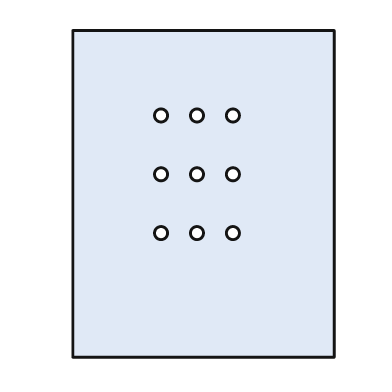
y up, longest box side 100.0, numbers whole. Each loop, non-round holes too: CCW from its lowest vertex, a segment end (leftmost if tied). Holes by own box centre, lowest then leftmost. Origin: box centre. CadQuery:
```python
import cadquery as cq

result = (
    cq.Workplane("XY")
    .moveTo(-40.0, -50.0)
    .lineTo(40.0, -50.0)
    .lineTo(40.0, 50.0)
    .lineTo(-40.0, 50.0)
    .close()
    .moveTo(-13.0, -12.0)
    .circle(2.0)
    .moveTo(-2.0, -12.0)
    .circle(2.0)
    .moveTo(9.0, -12.0)
    .circle(2.0)
    .moveTo(-13.0, 6.0)
    .circle(2.0)
    .moveTo(-2.0, 6.0)
    .circle(2.0)
    .moveTo(9.0, 6.0)
    .circle(2.0)
    .moveTo(-13.0, 24.0)
    .circle(2.0)
    .moveTo(-2.0, 24.0)
    .circle(2.0)
    .moveTo(9.0, 24.0)
    .circle(2.0)
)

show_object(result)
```